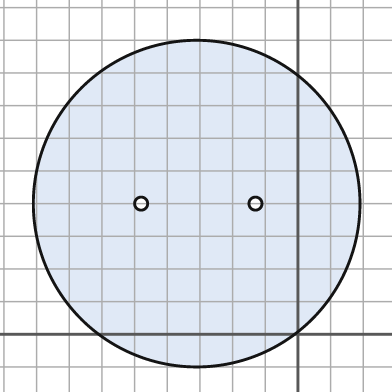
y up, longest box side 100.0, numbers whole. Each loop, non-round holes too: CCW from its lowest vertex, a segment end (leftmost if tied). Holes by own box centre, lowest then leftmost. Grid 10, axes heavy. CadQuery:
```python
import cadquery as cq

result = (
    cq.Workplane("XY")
    .moveTo(-31.0, 40.0)
    .circle(50.0)
    .moveTo(-48.0, 40.0)
    .circle(2.0)
    .moveTo(-13.0, 40.0)
    .circle(2.0)
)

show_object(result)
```